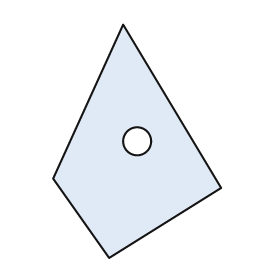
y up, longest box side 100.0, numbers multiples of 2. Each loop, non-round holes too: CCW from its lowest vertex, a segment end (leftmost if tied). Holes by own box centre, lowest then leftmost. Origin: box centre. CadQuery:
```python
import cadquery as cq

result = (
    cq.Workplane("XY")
    .moveTo(-12.0, -50.0)
    .lineTo(36.0, -20.0)
    .lineTo(-6.0, 50.0)
    .lineTo(-36.0, -16.0)
    .close()
    .moveTo(0.0, 0.0)
    .circle(6.0)
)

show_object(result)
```